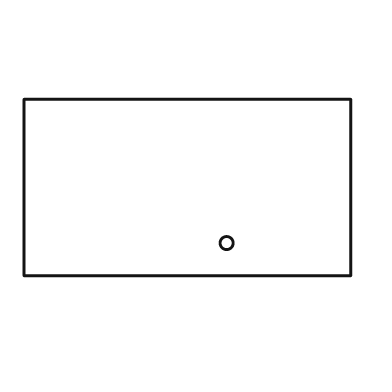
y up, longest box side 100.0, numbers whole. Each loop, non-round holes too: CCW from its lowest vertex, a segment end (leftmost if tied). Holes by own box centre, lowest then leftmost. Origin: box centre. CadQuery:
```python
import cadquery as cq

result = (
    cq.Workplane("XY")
    .moveTo(-50.0, -27.0)
    .lineTo(50.0, -27.0)
    .lineTo(50.0, 27.0)
    .lineTo(-50.0, 27.0)
    .close()
    .moveTo(12.0, -17.0)
    .circle(2.0)
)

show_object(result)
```